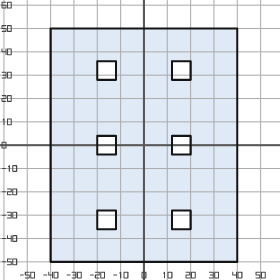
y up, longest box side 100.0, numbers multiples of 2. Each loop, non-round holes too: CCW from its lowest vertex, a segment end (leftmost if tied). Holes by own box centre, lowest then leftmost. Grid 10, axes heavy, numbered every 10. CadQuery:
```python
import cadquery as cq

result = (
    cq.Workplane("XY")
    .moveTo(-40.0, -50.0)
    .lineTo(40.0, -50.0)
    .lineTo(40.0, 50.0)
    .lineTo(-40.0, 50.0)
    .close()
    .moveTo(-20.0, -36.0)
    .lineTo(-12.0, -36.0)
    .lineTo(-12.0, -28.0)
    .lineTo(-20.0, -28.0)
    .close()
    .moveTo(12.0, -36.0)
    .lineTo(20.0, -36.0)
    .lineTo(20.0, -28.0)
    .lineTo(12.0, -28.0)
    .close()
    .moveTo(-20.0, -4.0)
    .lineTo(-12.0, -4.0)
    .lineTo(-12.0, 4.0)
    .lineTo(-20.0, 4.0)
    .close()
    .moveTo(12.0, -4.0)
    .lineTo(20.0, -4.0)
    .lineTo(20.0, 4.0)
    .lineTo(12.0, 4.0)
    .close()
    .moveTo(-20.0, 28.0)
    .lineTo(-12.0, 28.0)
    .lineTo(-12.0, 36.0)
    .lineTo(-20.0, 36.0)
    .close()
    .moveTo(12.0, 28.0)
    .lineTo(20.0, 28.0)
    .lineTo(20.0, 36.0)
    .lineTo(12.0, 36.0)
    .close()
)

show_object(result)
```